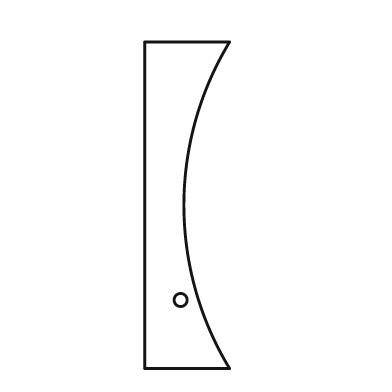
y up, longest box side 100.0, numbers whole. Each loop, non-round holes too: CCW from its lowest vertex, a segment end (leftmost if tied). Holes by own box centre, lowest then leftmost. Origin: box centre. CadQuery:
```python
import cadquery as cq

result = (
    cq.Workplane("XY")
    .moveTo(-13.0, -50.0)
    .lineTo(13.0, -50.0)
    .threePointArc((-1.0, 0.0), (13.0, 50.0))
    .lineTo(-13.0, 50.0)
    .close()
    .moveTo(-2.0, -29.0)
    .circle(2.0)
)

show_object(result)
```